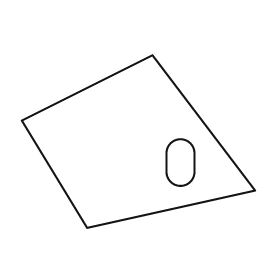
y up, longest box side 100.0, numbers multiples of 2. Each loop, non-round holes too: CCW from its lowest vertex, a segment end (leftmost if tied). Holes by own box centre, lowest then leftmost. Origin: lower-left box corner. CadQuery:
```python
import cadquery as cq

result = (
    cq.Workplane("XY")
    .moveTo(28.0, 0.0)
    .lineTo(100.0, 16.0)
    .lineTo(56.0, 74.0)
    .lineTo(0.0, 46.0)
    .close()
    .moveTo(62.0, 24.0)
    .threePointArc((68.0, 18.0), (74.0, 24.0))
    .lineTo(74.0, 32.0)
    .threePointArc((68.0, 38.0), (62.0, 32.0))
    .close()
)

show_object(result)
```